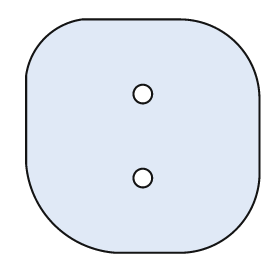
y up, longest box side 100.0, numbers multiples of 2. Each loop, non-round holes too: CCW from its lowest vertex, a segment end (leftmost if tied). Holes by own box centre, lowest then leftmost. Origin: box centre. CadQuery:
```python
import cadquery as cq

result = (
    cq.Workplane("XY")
    .moveTo(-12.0, -50.0)
    .lineTo(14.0, -50.0)
    .threePointArc((40.0, -40.0), (50.0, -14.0))
    .lineTo(50.0, 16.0)
    .threePointArc((40.0, 40.0), (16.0, 50.0))
    .lineTo(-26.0, 50.0)
    .threePointArc((-42.0, 42.0), (-50.0, 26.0))
    .lineTo(-50.0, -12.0)
    .threePointArc((-38.0, -38.0), (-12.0, -50.0))
    .close()
    .moveTo(0.0, -18.0)
    .circle(4.0)
    .moveTo(0.0, 18.0)
    .circle(4.0)
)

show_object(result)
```